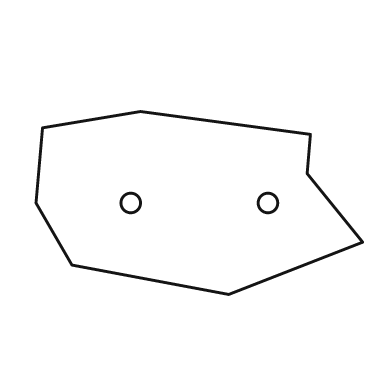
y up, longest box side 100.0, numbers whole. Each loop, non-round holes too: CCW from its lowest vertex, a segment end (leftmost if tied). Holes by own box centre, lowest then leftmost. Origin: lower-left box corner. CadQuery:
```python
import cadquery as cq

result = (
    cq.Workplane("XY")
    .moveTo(59.0, 0.0)
    .lineTo(100.0, 16.0)
    .lineTo(83.0, 37.0)
    .lineTo(84.0, 49.0)
    .lineTo(32.0, 56.0)
    .lineTo(2.0, 51.0)
    .lineTo(0.0, 28.0)
    .lineTo(11.0, 9.0)
    .close()
    .moveTo(29.0, 28.0)
    .circle(3.0)
    .moveTo(71.0, 28.0)
    .circle(3.0)
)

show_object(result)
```